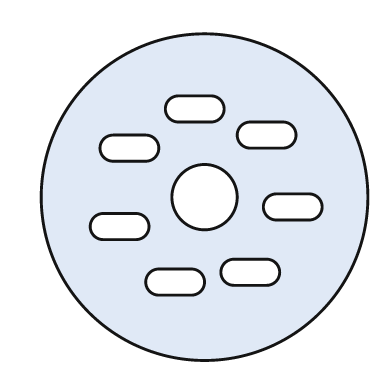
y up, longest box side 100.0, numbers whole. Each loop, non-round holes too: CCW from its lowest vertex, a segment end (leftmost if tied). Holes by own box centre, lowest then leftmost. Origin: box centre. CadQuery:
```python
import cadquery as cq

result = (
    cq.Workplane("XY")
    .moveTo(0.0, 0.0)
    .circle(50.0)
    .moveTo(-14.0, -30.0)
    .lineTo(-4.0, -30.0)
    .threePointArc((0.0, -26.0), (-4.0, -22.0))
    .lineTo(-14.0, -22.0)
    .threePointArc((-18.0, -26.0), (-14.0, -30.0))
    .close()
    .moveTo(9.0, -27.0)
    .lineTo(19.0, -27.0)
    .threePointArc((23.0, -23.0), (19.0, -19.0))
    .lineTo(9.0, -19.0)
    .threePointArc((5.0, -23.0), (9.0, -27.0))
    .close()
    .moveTo(-31.0, -13.0)
    .lineTo(-21.0, -13.0)
    .threePointArc((-17.0, -9.0), (-21.0, -5.0))
    .lineTo(-31.0, -5.0)
    .threePointArc((-35.0, -9.0), (-31.0, -13.0))
    .close()
    .moveTo(22.0, -7.0)
    .lineTo(32.0, -7.0)
    .threePointArc((36.0, -3.0), (32.0, 1.0))
    .lineTo(22.0, 1.0)
    .threePointArc((18.0, -3.0), (22.0, -7.0))
    .close()
    .moveTo(0.0, 0.0)
    .circle(10.0)
    .moveTo(-28.0, 11.0)
    .lineTo(-18.0, 11.0)
    .threePointArc((-14.0, 15.0), (-18.0, 19.0))
    .lineTo(-28.0, 19.0)
    .threePointArc((-32.0, 15.0), (-28.0, 11.0))
    .close()
    .moveTo(14.0, 15.0)
    .lineTo(24.0, 15.0)
    .threePointArc((28.0, 19.0), (24.0, 23.0))
    .lineTo(14.0, 23.0)
    .threePointArc((10.0, 19.0), (14.0, 15.0))
    .close()
    .moveTo(-8.0, 23.0)
    .lineTo(2.0, 23.0)
    .threePointArc((6.0, 27.0), (2.0, 31.0))
    .lineTo(-8.0, 31.0)
    .threePointArc((-12.0, 27.0), (-8.0, 23.0))
    .close()
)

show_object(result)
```